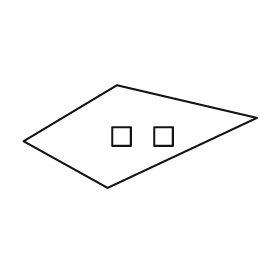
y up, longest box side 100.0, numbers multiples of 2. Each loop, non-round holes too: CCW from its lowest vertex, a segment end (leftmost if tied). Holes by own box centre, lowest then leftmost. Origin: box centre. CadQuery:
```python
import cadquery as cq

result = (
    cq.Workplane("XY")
    .moveTo(-14.0, -22.0)
    .lineTo(50.0, 8.0)
    .lineTo(-10.0, 22.0)
    .lineTo(-50.0, -2.0)
    .close()
    .moveTo(-12.0, -4.0)
    .lineTo(-4.0, -4.0)
    .lineTo(-4.0, 4.0)
    .lineTo(-12.0, 4.0)
    .close()
    .moveTo(6.0, -4.0)
    .lineTo(14.0, -4.0)
    .lineTo(14.0, 4.0)
    .lineTo(6.0, 4.0)
    .close()
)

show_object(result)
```